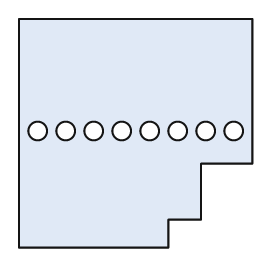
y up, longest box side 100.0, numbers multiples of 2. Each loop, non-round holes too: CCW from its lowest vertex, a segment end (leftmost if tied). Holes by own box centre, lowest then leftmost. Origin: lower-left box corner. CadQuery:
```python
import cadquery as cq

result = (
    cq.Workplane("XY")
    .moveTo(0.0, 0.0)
    .lineTo(64.0, 0.0)
    .lineTo(64.0, 12.0)
    .lineTo(78.0, 12.0)
    .lineTo(78.0, 36.0)
    .lineTo(100.0, 36.0)
    .lineTo(100.0, 98.0)
    .lineTo(0.0, 98.0)
    .close()
    .moveTo(8.0, 50.0)
    .circle(4.0)
    .moveTo(20.0, 50.0)
    .circle(4.0)
    .moveTo(32.0, 50.0)
    .circle(4.0)
    .moveTo(44.0, 50.0)
    .circle(4.0)
    .moveTo(56.0, 50.0)
    .circle(4.0)
    .moveTo(68.0, 50.0)
    .circle(4.0)
    .moveTo(80.0, 50.0)
    .circle(4.0)
    .moveTo(92.0, 50.0)
    .circle(4.0)
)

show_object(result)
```